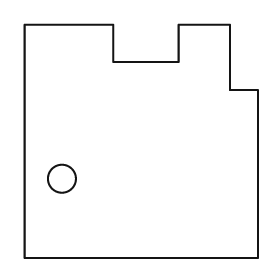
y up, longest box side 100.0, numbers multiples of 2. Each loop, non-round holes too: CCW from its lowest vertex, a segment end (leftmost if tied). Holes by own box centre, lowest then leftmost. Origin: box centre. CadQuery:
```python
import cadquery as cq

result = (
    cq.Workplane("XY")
    .moveTo(-50.0, -50.0)
    .lineTo(50.0, -50.0)
    .lineTo(50.0, 22.0)
    .lineTo(38.0, 22.0)
    .lineTo(38.0, 50.0)
    .lineTo(16.0, 50.0)
    .lineTo(16.0, 34.0)
    .lineTo(-12.0, 34.0)
    .lineTo(-12.0, 50.0)
    .lineTo(-50.0, 50.0)
    .close()
    .moveTo(-34.0, -16.0)
    .circle(6.0)
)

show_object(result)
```